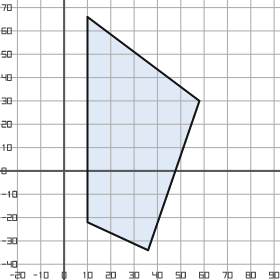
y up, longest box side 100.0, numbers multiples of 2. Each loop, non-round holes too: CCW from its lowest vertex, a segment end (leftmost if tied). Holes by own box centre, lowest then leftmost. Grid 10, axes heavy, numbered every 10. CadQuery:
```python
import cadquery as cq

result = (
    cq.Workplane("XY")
    .moveTo(36.0, -34.0)
    .lineTo(58.0, 30.0)
    .lineTo(10.0, 66.0)
    .lineTo(10.0, -22.0)
    .close()
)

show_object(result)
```